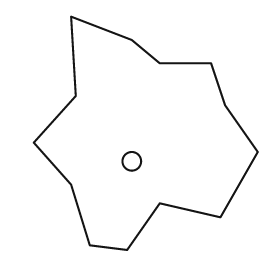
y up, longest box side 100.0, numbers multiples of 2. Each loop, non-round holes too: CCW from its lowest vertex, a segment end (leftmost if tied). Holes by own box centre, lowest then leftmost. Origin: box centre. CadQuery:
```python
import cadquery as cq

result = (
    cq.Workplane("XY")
    .moveTo(-8.0, -50.0)
    .lineTo(6.0, -30.0)
    .lineTo(32.0, -36.0)
    .lineTo(48.0, -8.0)
    .lineTo(34.0, 12.0)
    .lineTo(28.0, 30.0)
    .lineTo(6.0, 30.0)
    .lineTo(-6.0, 40.0)
    .lineTo(-32.0, 50.0)
    .lineTo(-30.0, 16.0)
    .lineTo(-48.0, -4.0)
    .lineTo(-32.0, -22.0)
    .lineTo(-24.0, -48.0)
    .close()
    .moveTo(-6.0, -12.0)
    .circle(4.0)
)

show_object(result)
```